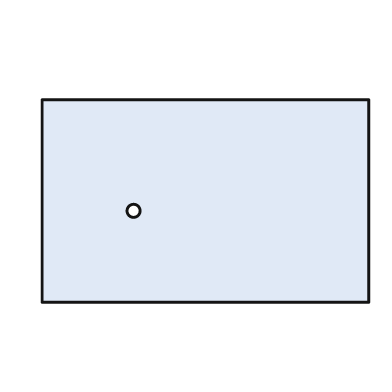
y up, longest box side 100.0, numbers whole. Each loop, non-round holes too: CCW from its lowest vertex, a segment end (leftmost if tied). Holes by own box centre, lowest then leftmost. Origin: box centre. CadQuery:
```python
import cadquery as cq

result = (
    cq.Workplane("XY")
    .moveTo(-50.0, -31.0)
    .lineTo(50.0, -31.0)
    .lineTo(50.0, 31.0)
    .lineTo(-50.0, 31.0)
    .close()
    .moveTo(-22.0, -3.0)
    .circle(2.0)
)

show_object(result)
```